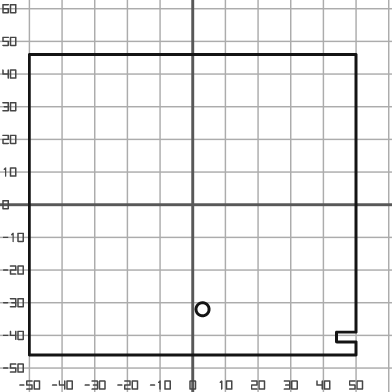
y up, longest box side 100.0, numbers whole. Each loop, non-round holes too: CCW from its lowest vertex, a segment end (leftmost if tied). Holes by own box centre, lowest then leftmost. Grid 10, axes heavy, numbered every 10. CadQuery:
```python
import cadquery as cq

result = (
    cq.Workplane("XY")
    .moveTo(-50.0, -46.0)
    .lineTo(50.0, -46.0)
    .lineTo(50.0, -42.0)
    .lineTo(44.0, -42.0)
    .lineTo(44.0, -39.0)
    .lineTo(50.0, -39.0)
    .lineTo(50.0, 46.0)
    .lineTo(-50.0, 46.0)
    .close()
    .moveTo(3.0, -32.0)
    .circle(2.0)
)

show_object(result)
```